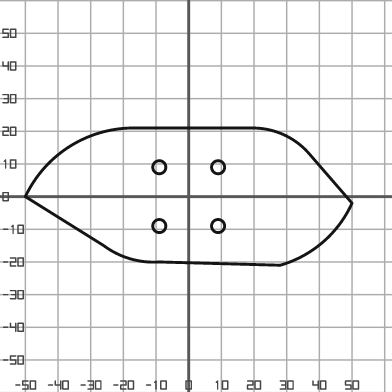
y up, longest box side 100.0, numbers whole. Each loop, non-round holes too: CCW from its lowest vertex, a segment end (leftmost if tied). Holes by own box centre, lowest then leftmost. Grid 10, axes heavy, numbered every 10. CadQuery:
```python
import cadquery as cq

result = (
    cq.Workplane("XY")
    .moveTo(28.0, -21.0)
    .threePointArc((41.0, -14.0), (50.0, -2.0))
    .lineTo(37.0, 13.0)
    .threePointArc((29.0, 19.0), (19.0, 21.0))
    .lineTo(-18.0, 21.0)
    .threePointArc((-37.0, 15.0), (-50.0, 0.0))
    .lineTo(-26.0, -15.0)
    .threePointArc((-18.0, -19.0), (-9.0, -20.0))
    .close()
    .moveTo(-9.0, -9.0)
    .circle(2.0)
    .moveTo(9.0, -9.0)
    .circle(2.0)
    .moveTo(-9.0, 9.0)
    .circle(2.0)
    .moveTo(9.0, 9.0)
    .circle(2.0)
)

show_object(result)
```